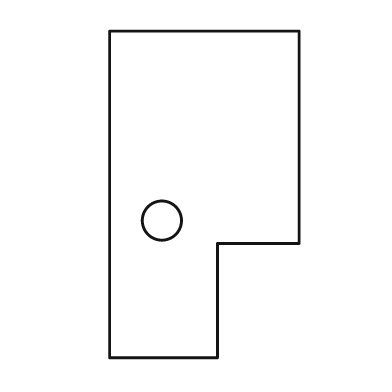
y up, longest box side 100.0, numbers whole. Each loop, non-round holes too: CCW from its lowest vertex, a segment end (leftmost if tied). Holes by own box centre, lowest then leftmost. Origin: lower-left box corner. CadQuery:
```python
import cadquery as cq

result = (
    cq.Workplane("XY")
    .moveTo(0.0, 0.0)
    .lineTo(33.0, 0.0)
    .lineTo(33.0, 35.0)
    .lineTo(58.0, 35.0)
    .lineTo(58.0, 100.0)
    .lineTo(0.0, 100.0)
    .close()
    .moveTo(16.0, 42.0)
    .circle(6.0)
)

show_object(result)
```